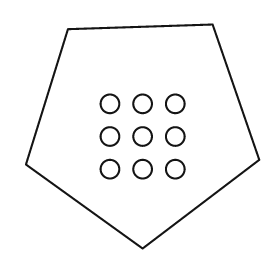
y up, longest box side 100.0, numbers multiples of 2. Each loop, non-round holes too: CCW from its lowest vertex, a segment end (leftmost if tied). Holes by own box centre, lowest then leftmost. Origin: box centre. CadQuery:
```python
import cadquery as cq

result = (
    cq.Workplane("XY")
    .moveTo(0.0, -48.0)
    .lineTo(50.0, -10.0)
    .lineTo(30.0, 48.0)
    .lineTo(-32.0, 46.0)
    .lineTo(-50.0, -12.0)
    .close()
    .moveTo(-14.0, -14.0)
    .circle(4.0)
    .moveTo(0.0, -14.0)
    .circle(4.0)
    .moveTo(14.0, -14.0)
    .circle(4.0)
    .moveTo(-14.0, 0.0)
    .circle(4.0)
    .moveTo(0.0, 0.0)
    .circle(4.0)
    .moveTo(14.0, 0.0)
    .circle(4.0)
    .moveTo(-14.0, 14.0)
    .circle(4.0)
    .moveTo(0.0, 14.0)
    .circle(4.0)
    .moveTo(14.0, 14.0)
    .circle(4.0)
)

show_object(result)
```